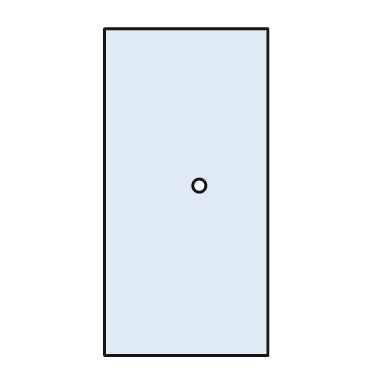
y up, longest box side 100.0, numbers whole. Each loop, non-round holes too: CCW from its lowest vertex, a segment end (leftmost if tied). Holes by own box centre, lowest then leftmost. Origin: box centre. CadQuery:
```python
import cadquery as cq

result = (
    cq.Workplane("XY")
    .moveTo(-25.0, -50.0)
    .lineTo(25.0, -50.0)
    .lineTo(25.0, 50.0)
    .lineTo(-25.0, 50.0)
    .close()
    .moveTo(4.0, 2.0)
    .circle(2.0)
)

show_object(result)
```